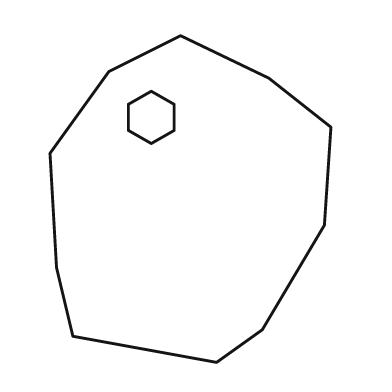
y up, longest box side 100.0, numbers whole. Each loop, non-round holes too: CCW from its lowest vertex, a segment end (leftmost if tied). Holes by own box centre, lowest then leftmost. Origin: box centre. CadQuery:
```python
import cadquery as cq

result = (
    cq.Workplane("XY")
    .moveTo(8.0, -50.0)
    .lineTo(22.0, -40.0)
    .lineTo(41.0, -8.0)
    .lineTo(43.0, 22.0)
    .lineTo(24.0, 37.0)
    .lineTo(-3.0, 50.0)
    .lineTo(-25.0, 39.0)
    .lineTo(-43.0, 14.0)
    .lineTo(-41.0, -21.0)
    .lineTo(-36.0, -42.0)
    .close()
    .moveTo(-12.0, 17.0)
    .lineTo(-5.0, 21.0)
    .lineTo(-5.0, 29.0)
    .lineTo(-12.0, 33.0)
    .lineTo(-19.0, 29.0)
    .lineTo(-19.0, 21.0)
    .close()
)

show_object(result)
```